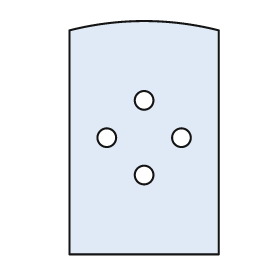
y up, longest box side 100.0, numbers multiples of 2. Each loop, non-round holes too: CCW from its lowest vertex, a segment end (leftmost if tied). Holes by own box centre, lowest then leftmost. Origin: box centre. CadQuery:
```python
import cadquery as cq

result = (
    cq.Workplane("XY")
    .moveTo(-32.0, -50.0)
    .lineTo(32.0, -50.0)
    .lineTo(32.0, 46.0)
    .threePointArc((0.0, 50.0), (-32.0, 46.0))
    .close()
    .moveTo(0.0, -16.0)
    .circle(4.0)
    .moveTo(-16.0, 0.0)
    .circle(4.0)
    .moveTo(16.0, 0.0)
    .circle(4.0)
    .moveTo(0.0, 16.0)
    .circle(4.0)
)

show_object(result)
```